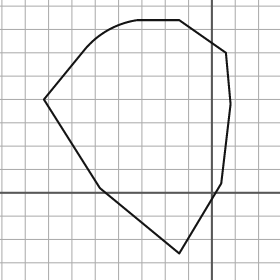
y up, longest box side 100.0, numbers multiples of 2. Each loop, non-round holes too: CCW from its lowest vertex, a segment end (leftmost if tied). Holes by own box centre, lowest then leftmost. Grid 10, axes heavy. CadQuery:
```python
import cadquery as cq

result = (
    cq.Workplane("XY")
    .moveTo(-14.0, -26.0)
    .lineTo(4.0, 4.0)
    .lineTo(8.0, 38.0)
    .lineTo(6.0, 60.0)
    .lineTo(-14.0, 74.0)
    .lineTo(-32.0, 74.0)
    .threePointArc((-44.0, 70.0), (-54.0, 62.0))
    .lineTo(-72.0, 40.0)
    .lineTo(-48.0, 2.0)
    .close()
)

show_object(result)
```